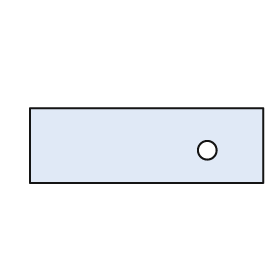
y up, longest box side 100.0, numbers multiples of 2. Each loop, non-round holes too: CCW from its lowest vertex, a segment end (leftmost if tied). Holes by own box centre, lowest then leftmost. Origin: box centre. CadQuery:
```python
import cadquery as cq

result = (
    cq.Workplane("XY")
    .moveTo(-50.0, -16.0)
    .lineTo(50.0, -16.0)
    .lineTo(50.0, 16.0)
    .lineTo(-50.0, 16.0)
    .close()
    .moveTo(26.0, -2.0)
    .circle(4.0)
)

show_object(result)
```